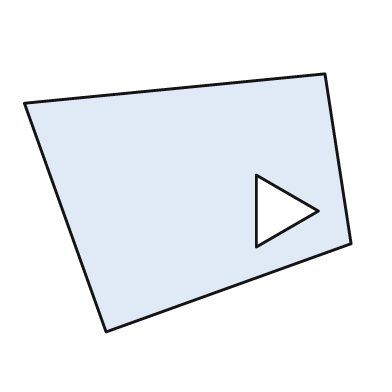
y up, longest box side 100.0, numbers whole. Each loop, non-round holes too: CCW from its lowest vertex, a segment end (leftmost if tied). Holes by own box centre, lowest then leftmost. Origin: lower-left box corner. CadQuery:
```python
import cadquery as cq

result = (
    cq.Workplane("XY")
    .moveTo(25.0, 0.0)
    .lineTo(100.0, 27.0)
    .lineTo(92.0, 79.0)
    .lineTo(0.0, 70.0)
    .close()
    .moveTo(71.0, 26.0)
    .lineTo(90.0, 37.0)
    .lineTo(71.0, 48.0)
    .close()
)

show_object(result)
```